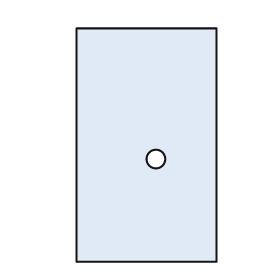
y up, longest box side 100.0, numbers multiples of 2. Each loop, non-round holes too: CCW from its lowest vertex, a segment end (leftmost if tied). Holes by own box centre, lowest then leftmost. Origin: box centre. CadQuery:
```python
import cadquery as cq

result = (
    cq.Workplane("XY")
    .moveTo(-30.0, -50.0)
    .lineTo(30.0, -50.0)
    .lineTo(30.0, 50.0)
    .lineTo(-30.0, 50.0)
    .close()
    .moveTo(4.0, -6.0)
    .circle(4.0)
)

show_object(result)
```